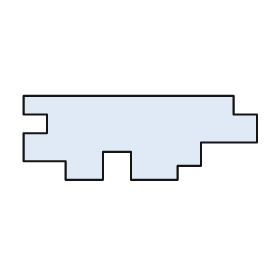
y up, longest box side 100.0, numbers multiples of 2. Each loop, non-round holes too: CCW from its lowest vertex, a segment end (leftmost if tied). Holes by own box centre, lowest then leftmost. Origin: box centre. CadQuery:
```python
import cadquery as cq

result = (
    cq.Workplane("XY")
    .moveTo(-32.0, -18.0)
    .lineTo(-16.0, -18.0)
    .lineTo(-16.0, -6.0)
    .lineTo(-4.0, -6.0)
    .lineTo(-4.0, -18.0)
    .lineTo(16.0, -18.0)
    .lineTo(16.0, -12.0)
    .lineTo(26.0, -12.0)
    .lineTo(26.0, -2.0)
    .lineTo(50.0, -2.0)
    .lineTo(50.0, 10.0)
    .lineTo(40.0, 10.0)
    .lineTo(40.0, 18.0)
    .lineTo(-50.0, 18.0)
    .lineTo(-50.0, 10.0)
    .lineTo(-40.0, 10.0)
    .lineTo(-40.0, 2.0)
    .lineTo(-50.0, 2.0)
    .lineTo(-50.0, -10.0)
    .lineTo(-32.0, -10.0)
    .close()
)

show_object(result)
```